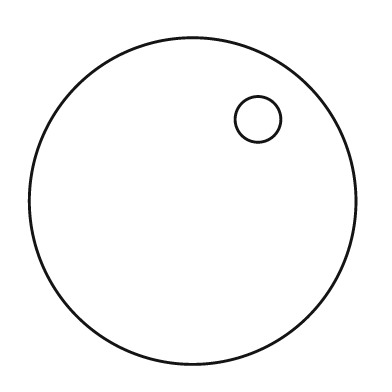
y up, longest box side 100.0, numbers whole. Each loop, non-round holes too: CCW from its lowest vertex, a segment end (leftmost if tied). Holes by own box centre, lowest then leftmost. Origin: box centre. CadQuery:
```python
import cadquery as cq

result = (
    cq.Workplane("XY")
    .moveTo(0.0, 0.0)
    .circle(50.0)
    .moveTo(20.0, 25.0)
    .circle(7.0)
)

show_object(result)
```